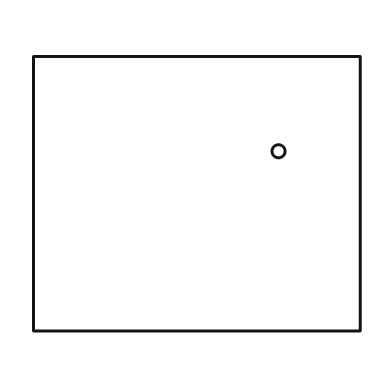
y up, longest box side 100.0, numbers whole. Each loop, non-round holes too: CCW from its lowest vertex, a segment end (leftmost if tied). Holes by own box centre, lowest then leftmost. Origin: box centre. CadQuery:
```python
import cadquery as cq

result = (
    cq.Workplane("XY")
    .moveTo(-50.0, -42.0)
    .lineTo(50.0, -42.0)
    .lineTo(50.0, 42.0)
    .lineTo(-50.0, 42.0)
    .close()
    .moveTo(25.0, 13.0)
    .circle(2.0)
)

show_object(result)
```